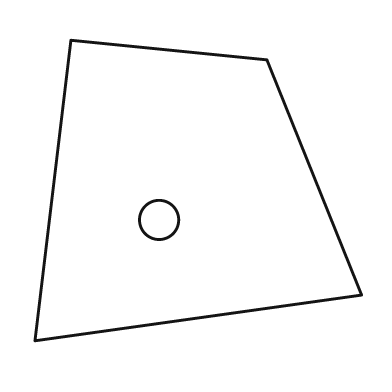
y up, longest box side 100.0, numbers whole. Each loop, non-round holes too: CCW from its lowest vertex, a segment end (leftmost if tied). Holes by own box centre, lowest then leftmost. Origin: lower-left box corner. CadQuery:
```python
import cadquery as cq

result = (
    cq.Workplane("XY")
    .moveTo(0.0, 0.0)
    .lineTo(100.0, 14.0)
    .lineTo(71.0, 86.0)
    .lineTo(11.0, 92.0)
    .close()
    .moveTo(38.0, 37.0)
    .circle(6.0)
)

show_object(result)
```